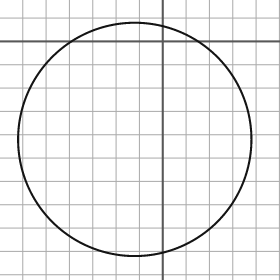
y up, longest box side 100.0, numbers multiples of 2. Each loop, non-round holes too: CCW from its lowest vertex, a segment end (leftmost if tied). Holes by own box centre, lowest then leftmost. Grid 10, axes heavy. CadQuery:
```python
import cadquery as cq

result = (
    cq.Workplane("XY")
    .moveTo(-12.0, -42.0)
    .circle(50.0)
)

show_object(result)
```